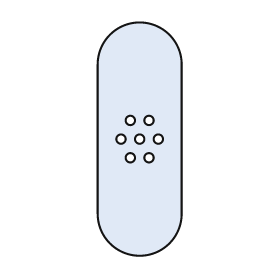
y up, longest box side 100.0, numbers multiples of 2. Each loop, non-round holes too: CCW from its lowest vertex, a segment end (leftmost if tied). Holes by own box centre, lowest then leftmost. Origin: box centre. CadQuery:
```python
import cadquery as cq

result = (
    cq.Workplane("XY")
    .moveTo(-18.0, -32.0)
    .threePointArc((0.0, -50.0), (18.0, -32.0))
    .lineTo(18.0, 32.0)
    .threePointArc((0.0, 50.0), (-18.0, 32.0))
    .close()
    .moveTo(-4.0, -8.0)
    .circle(2.0)
    .moveTo(4.0, -8.0)
    .circle(2.0)
    .moveTo(-8.0, 0.0)
    .circle(2.0)
    .moveTo(0.0, 0.0)
    .circle(2.0)
    .moveTo(8.0, 0.0)
    .circle(2.0)
    .moveTo(-4.0, 8.0)
    .circle(2.0)
    .moveTo(4.0, 8.0)
    .circle(2.0)
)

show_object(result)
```